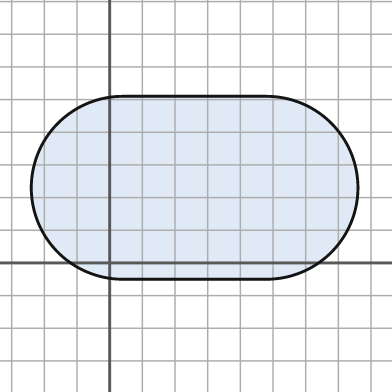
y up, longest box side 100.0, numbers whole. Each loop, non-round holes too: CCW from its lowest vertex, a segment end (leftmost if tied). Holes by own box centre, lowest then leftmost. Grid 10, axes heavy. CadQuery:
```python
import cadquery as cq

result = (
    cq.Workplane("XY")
    .moveTo(4.0, -5.0)
    .lineTo(48.0, -5.0)
    .threePointArc((76.0, 23.0), (48.0, 51.0))
    .lineTo(4.0, 51.0)
    .threePointArc((-24.0, 23.0), (4.0, -5.0))
    .close()
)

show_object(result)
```